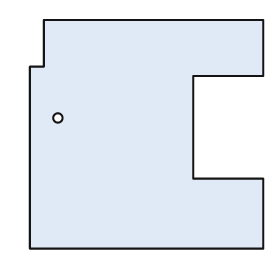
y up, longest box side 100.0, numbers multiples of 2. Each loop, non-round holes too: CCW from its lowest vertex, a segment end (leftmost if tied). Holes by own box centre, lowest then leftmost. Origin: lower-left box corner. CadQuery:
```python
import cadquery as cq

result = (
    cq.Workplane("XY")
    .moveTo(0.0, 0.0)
    .lineTo(100.0, 0.0)
    .lineTo(100.0, 30.0)
    .lineTo(70.0, 30.0)
    .lineTo(70.0, 74.0)
    .lineTo(100.0, 74.0)
    .lineTo(100.0, 98.0)
    .lineTo(6.0, 98.0)
    .lineTo(6.0, 78.0)
    .lineTo(0.0, 78.0)
    .close()
    .moveTo(12.0, 56.0)
    .circle(2.0)
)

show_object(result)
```